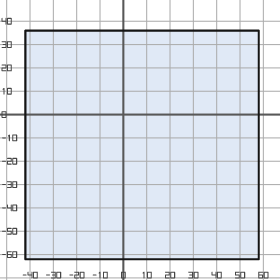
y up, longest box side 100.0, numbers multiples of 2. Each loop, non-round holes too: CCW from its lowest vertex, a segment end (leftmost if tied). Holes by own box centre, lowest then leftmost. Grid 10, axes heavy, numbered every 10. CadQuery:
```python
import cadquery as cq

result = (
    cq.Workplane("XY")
    .moveTo(-42.0, -62.0)
    .lineTo(58.0, -62.0)
    .lineTo(58.0, 36.0)
    .lineTo(-42.0, 36.0)
    .close()
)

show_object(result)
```